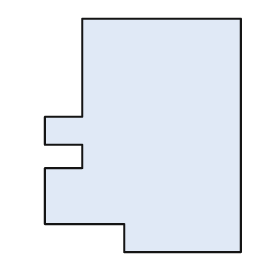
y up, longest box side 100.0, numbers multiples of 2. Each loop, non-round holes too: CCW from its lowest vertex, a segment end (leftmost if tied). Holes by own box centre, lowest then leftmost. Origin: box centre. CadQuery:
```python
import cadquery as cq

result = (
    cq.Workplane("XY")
    .moveTo(-8.0, -50.0)
    .lineTo(42.0, -50.0)
    .lineTo(42.0, 50.0)
    .lineTo(-26.0, 50.0)
    .lineTo(-26.0, 8.0)
    .lineTo(-42.0, 8.0)
    .lineTo(-42.0, -4.0)
    .lineTo(-26.0, -4.0)
    .lineTo(-26.0, -14.0)
    .lineTo(-42.0, -14.0)
    .lineTo(-42.0, -38.0)
    .lineTo(-8.0, -38.0)
    .close()
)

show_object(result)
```